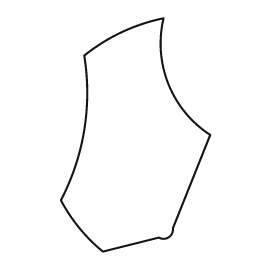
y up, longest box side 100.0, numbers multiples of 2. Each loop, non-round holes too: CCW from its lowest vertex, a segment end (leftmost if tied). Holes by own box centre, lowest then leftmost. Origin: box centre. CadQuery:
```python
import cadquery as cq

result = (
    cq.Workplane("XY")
    .moveTo(-14.0, -50.0)
    .lineTo(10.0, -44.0)
    .threePointArc((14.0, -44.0), (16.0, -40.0))
    .lineTo(32.0, 0.0)
    .threePointArc((14.0, 22.0), (12.0, 50.0))
    .threePointArc((-6.0, 44.0), (-22.0, 34.0))
    .threePointArc((-22.0, 2.0), (-32.0, -28.0))
    .threePointArc((-24.0, -40.0), (-14.0, -50.0))
    .close()
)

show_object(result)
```